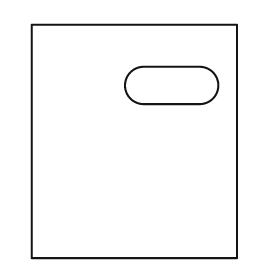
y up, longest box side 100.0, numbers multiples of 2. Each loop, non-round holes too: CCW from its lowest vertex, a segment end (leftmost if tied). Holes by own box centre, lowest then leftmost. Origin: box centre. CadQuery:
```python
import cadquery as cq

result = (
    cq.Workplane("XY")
    .moveTo(-44.0, -50.0)
    .lineTo(44.0, -50.0)
    .lineTo(44.0, 50.0)
    .lineTo(-44.0, 50.0)
    .close()
    .moveTo(4.0, 16.0)
    .lineTo(28.0, 16.0)
    .threePointArc((36.0, 24.0), (28.0, 32.0))
    .lineTo(4.0, 32.0)
    .threePointArc((-4.0, 24.0), (4.0, 16.0))
    .close()
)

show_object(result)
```